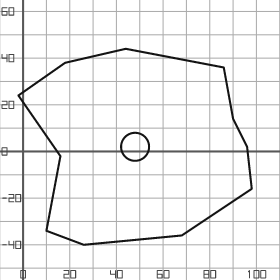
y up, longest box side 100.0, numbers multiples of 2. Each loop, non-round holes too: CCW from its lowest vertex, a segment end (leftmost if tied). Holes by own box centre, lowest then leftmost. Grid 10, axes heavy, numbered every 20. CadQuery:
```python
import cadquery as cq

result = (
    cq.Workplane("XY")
    .moveTo(26.0, -40.0)
    .lineTo(68.0, -36.0)
    .lineTo(98.0, -16.0)
    .lineTo(96.0, 2.0)
    .lineTo(90.0, 14.0)
    .lineTo(86.0, 36.0)
    .lineTo(44.0, 44.0)
    .lineTo(18.0, 38.0)
    .lineTo(-2.0, 24.0)
    .lineTo(16.0, -2.0)
    .lineTo(10.0, -34.0)
    .close()
    .moveTo(48.0, 2.0)
    .circle(6.0)
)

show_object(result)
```